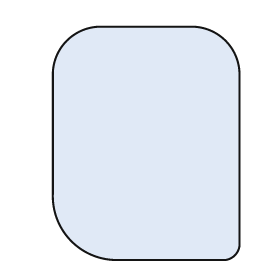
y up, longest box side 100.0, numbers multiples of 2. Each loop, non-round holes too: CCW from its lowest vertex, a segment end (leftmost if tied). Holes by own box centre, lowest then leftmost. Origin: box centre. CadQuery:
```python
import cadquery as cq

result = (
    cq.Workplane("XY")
    .moveTo(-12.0, -50.0)
    .lineTo(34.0, -50.0)
    .threePointArc((38.0, -48.0), (40.0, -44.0))
    .lineTo(40.0, 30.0)
    .threePointArc((34.0, 44.0), (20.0, 50.0))
    .lineTo(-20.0, 50.0)
    .threePointArc((-34.0, 44.0), (-40.0, 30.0))
    .lineTo(-40.0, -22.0)
    .threePointArc((-32.0, -42.0), (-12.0, -50.0))
    .close()
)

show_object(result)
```